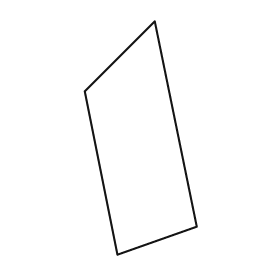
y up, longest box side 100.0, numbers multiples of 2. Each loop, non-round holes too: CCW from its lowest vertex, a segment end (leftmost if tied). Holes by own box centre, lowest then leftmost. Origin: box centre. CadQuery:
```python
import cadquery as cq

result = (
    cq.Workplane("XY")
    .moveTo(-10.0, -50.0)
    .lineTo(24.0, -38.0)
    .lineTo(6.0, 50.0)
    .lineTo(-24.0, 20.0)
    .close()
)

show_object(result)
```